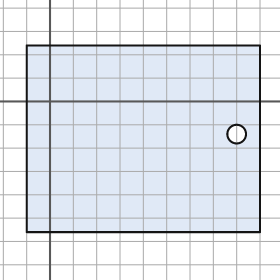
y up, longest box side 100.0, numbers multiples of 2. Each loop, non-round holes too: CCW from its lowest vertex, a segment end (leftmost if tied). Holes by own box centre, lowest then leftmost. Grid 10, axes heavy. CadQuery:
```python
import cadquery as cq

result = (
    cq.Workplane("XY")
    .moveTo(-10.0, -56.0)
    .lineTo(90.0, -56.0)
    .lineTo(90.0, 24.0)
    .lineTo(-10.0, 24.0)
    .close()
    .moveTo(80.0, -14.0)
    .circle(4.0)
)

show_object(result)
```